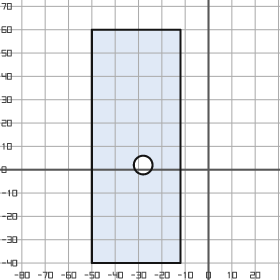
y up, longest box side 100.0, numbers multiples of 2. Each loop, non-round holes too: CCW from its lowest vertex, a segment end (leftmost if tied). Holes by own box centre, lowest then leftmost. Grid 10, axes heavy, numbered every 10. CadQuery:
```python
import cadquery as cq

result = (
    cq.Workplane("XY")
    .moveTo(-50.0, -40.0)
    .lineTo(-12.0, -40.0)
    .lineTo(-12.0, 60.0)
    .lineTo(-50.0, 60.0)
    .close()
    .moveTo(-28.0, 2.0)
    .circle(4.0)
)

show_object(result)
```